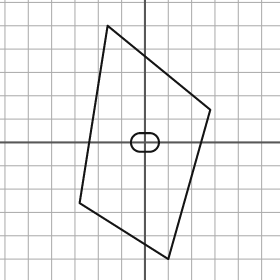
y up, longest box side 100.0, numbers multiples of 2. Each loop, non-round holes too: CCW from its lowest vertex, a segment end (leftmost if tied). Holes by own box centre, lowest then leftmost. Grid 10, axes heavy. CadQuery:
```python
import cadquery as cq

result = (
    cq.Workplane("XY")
    .moveTo(10.0, -50.0)
    .lineTo(28.0, 14.0)
    .lineTo(-16.0, 50.0)
    .lineTo(-28.0, -26.0)
    .close()
    .moveTo(-2.0, -4.0)
    .lineTo(2.0, -4.0)
    .threePointArc((6.0, 0.0), (2.0, 4.0))
    .lineTo(-2.0, 4.0)
    .threePointArc((-6.0, 0.0), (-2.0, -4.0))
    .close()
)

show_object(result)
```